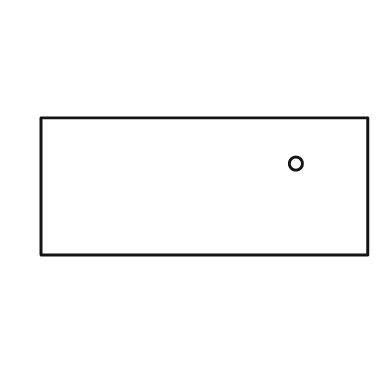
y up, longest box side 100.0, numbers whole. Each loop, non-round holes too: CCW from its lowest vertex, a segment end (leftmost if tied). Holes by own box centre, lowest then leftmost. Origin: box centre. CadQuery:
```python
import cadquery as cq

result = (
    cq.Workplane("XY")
    .moveTo(-50.0, -21.0)
    .lineTo(50.0, -21.0)
    .lineTo(50.0, 21.0)
    .lineTo(-50.0, 21.0)
    .close()
    .moveTo(28.0, 7.0)
    .circle(2.0)
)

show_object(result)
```